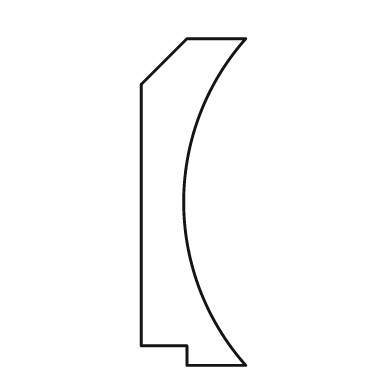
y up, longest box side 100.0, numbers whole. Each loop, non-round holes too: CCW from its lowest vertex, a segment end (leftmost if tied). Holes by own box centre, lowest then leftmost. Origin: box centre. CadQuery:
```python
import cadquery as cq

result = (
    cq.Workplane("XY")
    .moveTo(-2.0, -50.0)
    .lineTo(16.0, -50.0)
    .threePointArc((-3.0, 0.0), (16.0, 50.0))
    .lineTo(-2.0, 50.0)
    .lineTo(-16.0, 36.0)
    .lineTo(-16.0, -44.0)
    .lineTo(-2.0, -44.0)
    .close()
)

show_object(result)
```